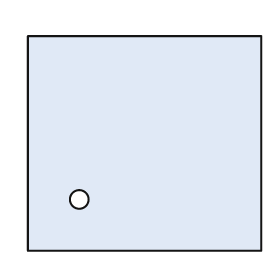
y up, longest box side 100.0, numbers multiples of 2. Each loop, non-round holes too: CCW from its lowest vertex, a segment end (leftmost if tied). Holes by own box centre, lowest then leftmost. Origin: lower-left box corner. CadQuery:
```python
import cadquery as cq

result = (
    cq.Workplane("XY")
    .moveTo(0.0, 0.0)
    .lineTo(100.0, 0.0)
    .lineTo(100.0, 92.0)
    .lineTo(0.0, 92.0)
    .close()
    .moveTo(22.0, 22.0)
    .circle(4.0)
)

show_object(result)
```